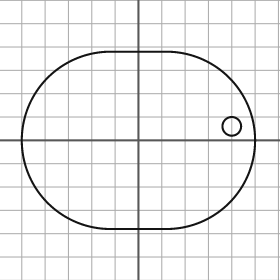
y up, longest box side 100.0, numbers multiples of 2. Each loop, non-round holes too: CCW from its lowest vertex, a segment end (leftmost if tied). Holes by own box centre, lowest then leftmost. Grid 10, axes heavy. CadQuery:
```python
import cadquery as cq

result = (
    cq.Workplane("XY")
    .moveTo(-12.0, -38.0)
    .lineTo(12.0, -38.0)
    .threePointArc((50.0, 0.0), (12.0, 38.0))
    .lineTo(-12.0, 38.0)
    .threePointArc((-50.0, 0.0), (-12.0, -38.0))
    .close()
    .moveTo(40.0, 6.0)
    .circle(4.0)
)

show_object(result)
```